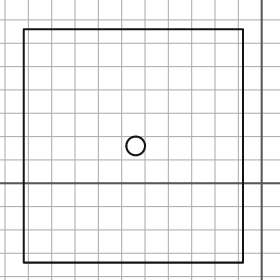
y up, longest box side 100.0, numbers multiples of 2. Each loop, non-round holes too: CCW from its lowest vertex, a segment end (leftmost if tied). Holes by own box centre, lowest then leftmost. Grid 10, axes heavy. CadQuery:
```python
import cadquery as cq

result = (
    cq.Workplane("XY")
    .moveTo(-102.0, -34.0)
    .lineTo(-8.0, -34.0)
    .lineTo(-8.0, 66.0)
    .lineTo(-102.0, 66.0)
    .close()
    .moveTo(-54.0, 16.0)
    .circle(4.0)
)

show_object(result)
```